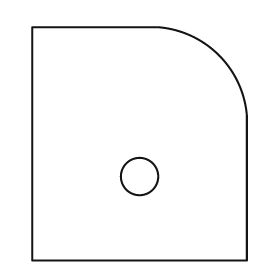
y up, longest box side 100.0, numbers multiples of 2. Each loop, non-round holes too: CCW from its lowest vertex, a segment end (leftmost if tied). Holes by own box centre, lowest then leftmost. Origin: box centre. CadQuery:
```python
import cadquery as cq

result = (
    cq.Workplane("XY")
    .moveTo(-46.0, -50.0)
    .lineTo(46.0, -50.0)
    .lineTo(46.0, 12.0)
    .threePointArc((34.0, 38.0), (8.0, 50.0))
    .lineTo(-46.0, 50.0)
    .close()
    .moveTo(0.0, -14.0)
    .circle(8.0)
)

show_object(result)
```